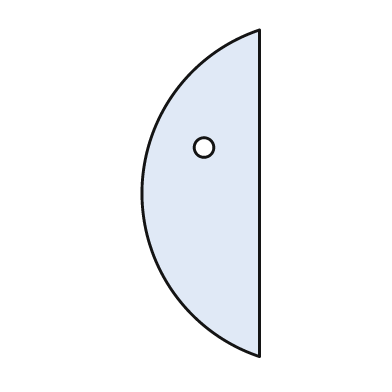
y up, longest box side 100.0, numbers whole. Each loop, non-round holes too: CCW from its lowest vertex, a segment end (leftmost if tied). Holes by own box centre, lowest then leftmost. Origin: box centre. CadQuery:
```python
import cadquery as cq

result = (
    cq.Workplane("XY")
    .moveTo(18.0, -50.0)
    .lineTo(18.0, 50.0)
    .threePointArc((-18.0, 0.0), (18.0, -50.0))
    .close()
    .moveTo(1.0, 14.0)
    .circle(3.0)
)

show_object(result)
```